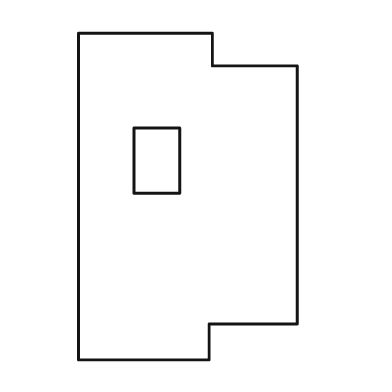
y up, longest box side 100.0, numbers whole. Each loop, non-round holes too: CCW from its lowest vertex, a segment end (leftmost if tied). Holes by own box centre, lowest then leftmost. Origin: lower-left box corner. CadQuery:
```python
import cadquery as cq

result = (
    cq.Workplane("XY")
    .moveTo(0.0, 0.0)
    .lineTo(40.0, 0.0)
    .lineTo(40.0, 11.0)
    .lineTo(67.0, 11.0)
    .lineTo(67.0, 90.0)
    .lineTo(41.0, 90.0)
    .lineTo(41.0, 100.0)
    .lineTo(0.0, 100.0)
    .close()
    .moveTo(17.0, 51.0)
    .lineTo(31.0, 51.0)
    .lineTo(31.0, 71.0)
    .lineTo(17.0, 71.0)
    .close()
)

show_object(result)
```